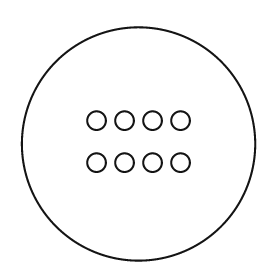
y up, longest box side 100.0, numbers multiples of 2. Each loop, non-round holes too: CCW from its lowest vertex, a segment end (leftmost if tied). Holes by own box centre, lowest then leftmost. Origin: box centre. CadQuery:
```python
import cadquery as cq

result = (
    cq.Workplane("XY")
    .moveTo(0.0, 0.0)
    .circle(50.0)
    .moveTo(-18.0, -8.0)
    .circle(4.0)
    .moveTo(-6.0, -8.0)
    .circle(4.0)
    .moveTo(6.0, -8.0)
    .circle(4.0)
    .moveTo(18.0, -8.0)
    .circle(4.0)
    .moveTo(-18.0, 10.0)
    .circle(4.0)
    .moveTo(-6.0, 10.0)
    .circle(4.0)
    .moveTo(6.0, 10.0)
    .circle(4.0)
    .moveTo(18.0, 10.0)
    .circle(4.0)
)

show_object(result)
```